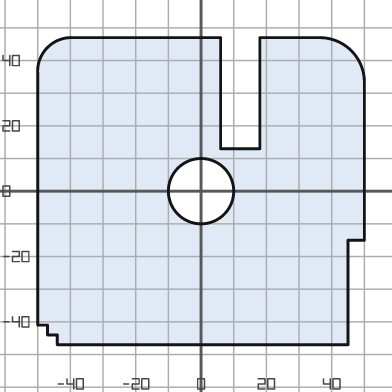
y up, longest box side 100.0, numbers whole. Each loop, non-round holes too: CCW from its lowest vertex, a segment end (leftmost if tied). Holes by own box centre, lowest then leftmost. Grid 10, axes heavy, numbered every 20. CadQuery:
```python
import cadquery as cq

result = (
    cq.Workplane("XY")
    .moveTo(-44.0, -47.0)
    .lineTo(45.0, -47.0)
    .lineTo(45.0, -15.0)
    .lineTo(50.0, -15.0)
    .lineTo(50.0, 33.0)
    .threePointArc((46.0, 43.0), (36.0, 47.0))
    .lineTo(18.0, 47.0)
    .lineTo(18.0, 13.0)
    .lineTo(6.0, 13.0)
    .lineTo(6.0, 47.0)
    .lineTo(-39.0, 47.0)
    .threePointArc((-47.0, 44.0), (-50.0, 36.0))
    .lineTo(-50.0, -41.0)
    .lineTo(-47.0, -41.0)
    .lineTo(-47.0, -44.0)
    .lineTo(-44.0, -44.0)
    .close()
    .moveTo(0.0, 0.0)
    .circle(10.0)
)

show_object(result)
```